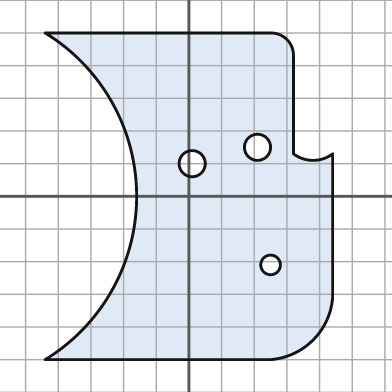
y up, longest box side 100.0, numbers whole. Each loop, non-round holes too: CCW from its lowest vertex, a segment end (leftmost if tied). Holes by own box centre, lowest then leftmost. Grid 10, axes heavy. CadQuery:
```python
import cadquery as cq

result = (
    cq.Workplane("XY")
    .moveTo(-44.0, -50.0)
    .lineTo(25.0, -50.0)
    .threePointArc((38.0, -44.0), (44.0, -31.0))
    .lineTo(44.0, 13.0)
    .threePointArc((38.0, 11.0), (32.0, 13.0))
    .lineTo(32.0, 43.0)
    .threePointArc((30.0, 48.0), (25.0, 50.0))
    .lineTo(-44.0, 50.0)
    .threePointArc((-16.0, 0.0), (-44.0, -50.0))
    .close()
    .moveTo(25.0, -21.0)
    .circle(3.0)
    .moveTo(1.0, 10.0)
    .circle(4.0)
    .moveTo(21.0, 15.0)
    .circle(4.0)
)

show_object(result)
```